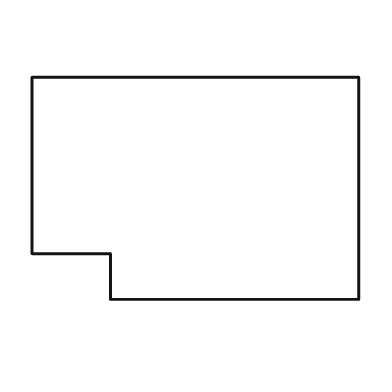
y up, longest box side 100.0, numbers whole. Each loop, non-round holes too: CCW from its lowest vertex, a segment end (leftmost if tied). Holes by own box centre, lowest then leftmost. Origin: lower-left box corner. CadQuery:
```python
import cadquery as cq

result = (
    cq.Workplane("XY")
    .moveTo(24.0, 0.0)
    .lineTo(100.0, 0.0)
    .lineTo(100.0, 68.0)
    .lineTo(0.0, 68.0)
    .lineTo(0.0, 14.0)
    .lineTo(24.0, 14.0)
    .close()
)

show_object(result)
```